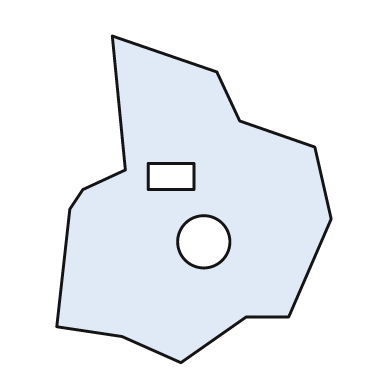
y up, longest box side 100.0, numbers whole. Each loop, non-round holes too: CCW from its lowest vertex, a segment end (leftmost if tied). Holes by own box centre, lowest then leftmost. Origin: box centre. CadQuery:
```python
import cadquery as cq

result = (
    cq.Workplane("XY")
    .moveTo(-4.0, -50.0)
    .lineTo(16.0, -36.0)
    .lineTo(29.0, -36.0)
    .lineTo(42.0, -6.0)
    .lineTo(37.0, 16.0)
    .lineTo(14.0, 24.0)
    .lineTo(7.0, 39.0)
    .lineTo(-25.0, 50.0)
    .lineTo(-21.0, 9.0)
    .lineTo(-34.0, 3.0)
    .lineTo(-38.0, -3.0)
    .lineTo(-42.0, -39.0)
    .lineTo(-22.0, -42.0)
    .close()
    .moveTo(3.0, -13.0)
    .circle(8.0)
    .moveTo(-14.0, 3.0)
    .lineTo(0.0, 3.0)
    .lineTo(0.0, 11.0)
    .lineTo(-14.0, 11.0)
    .close()
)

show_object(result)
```